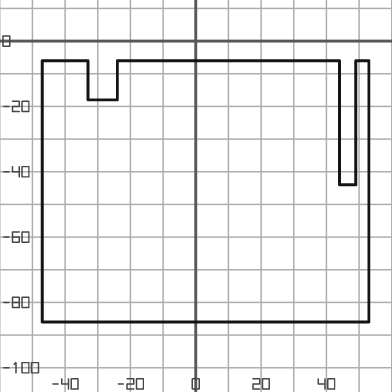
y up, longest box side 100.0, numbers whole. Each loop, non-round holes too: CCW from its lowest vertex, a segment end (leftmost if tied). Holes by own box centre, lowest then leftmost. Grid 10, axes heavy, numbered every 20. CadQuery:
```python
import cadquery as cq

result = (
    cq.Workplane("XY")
    .moveTo(-47.0, -86.0)
    .lineTo(53.0, -86.0)
    .lineTo(53.0, -6.0)
    .lineTo(49.0, -6.0)
    .lineTo(49.0, -44.0)
    .lineTo(44.0, -44.0)
    .lineTo(44.0, -6.0)
    .lineTo(-24.0, -6.0)
    .lineTo(-24.0, -18.0)
    .lineTo(-33.0, -18.0)
    .lineTo(-33.0, -6.0)
    .lineTo(-47.0, -6.0)
    .close()
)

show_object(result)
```